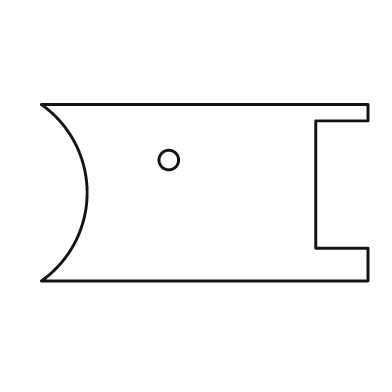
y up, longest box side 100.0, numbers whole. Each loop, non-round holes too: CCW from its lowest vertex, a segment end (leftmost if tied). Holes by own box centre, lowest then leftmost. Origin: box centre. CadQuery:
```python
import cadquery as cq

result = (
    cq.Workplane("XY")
    .moveTo(-50.0, -27.0)
    .lineTo(50.0, -27.0)
    .lineTo(50.0, -17.0)
    .lineTo(34.0, -17.0)
    .lineTo(34.0, 22.0)
    .lineTo(50.0, 22.0)
    .lineTo(50.0, 27.0)
    .lineTo(-50.0, 27.0)
    .threePointArc((-36.0, 0.0), (-50.0, -27.0))
    .close()
    .moveTo(-11.0, 10.0)
    .circle(3.0)
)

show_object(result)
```